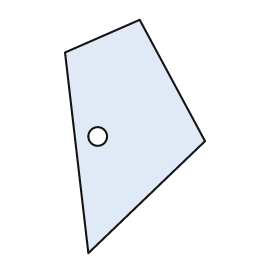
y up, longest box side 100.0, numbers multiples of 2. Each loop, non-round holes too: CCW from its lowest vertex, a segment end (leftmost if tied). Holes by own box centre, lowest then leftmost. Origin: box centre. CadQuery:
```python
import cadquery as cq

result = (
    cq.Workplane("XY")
    .moveTo(-20.0, -50.0)
    .lineTo(30.0, -2.0)
    .lineTo(2.0, 50.0)
    .lineTo(-30.0, 36.0)
    .close()
    .moveTo(-16.0, 0.0)
    .circle(4.0)
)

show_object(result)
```